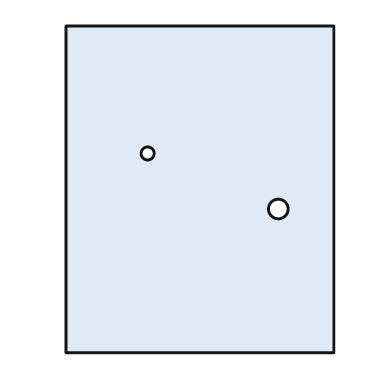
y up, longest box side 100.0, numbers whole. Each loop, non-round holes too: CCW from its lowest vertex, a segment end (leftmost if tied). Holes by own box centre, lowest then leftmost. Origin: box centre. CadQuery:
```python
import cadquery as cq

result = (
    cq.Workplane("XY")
    .moveTo(-41.0, -50.0)
    .lineTo(41.0, -50.0)
    .lineTo(41.0, 50.0)
    .lineTo(-41.0, 50.0)
    .close()
    .moveTo(24.0, -6.0)
    .circle(3.0)
    .moveTo(-16.0, 11.0)
    .circle(2.0)
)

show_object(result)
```